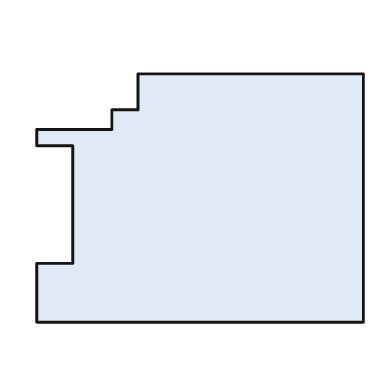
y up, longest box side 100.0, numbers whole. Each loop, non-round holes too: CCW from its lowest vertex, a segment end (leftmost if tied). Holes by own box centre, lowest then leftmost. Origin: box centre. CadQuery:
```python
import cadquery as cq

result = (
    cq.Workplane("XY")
    .moveTo(-50.0, -38.0)
    .lineTo(50.0, -38.0)
    .lineTo(50.0, 38.0)
    .lineTo(-19.0, 38.0)
    .lineTo(-19.0, 27.0)
    .lineTo(-27.0, 27.0)
    .lineTo(-27.0, 21.0)
    .lineTo(-50.0, 21.0)
    .lineTo(-50.0, 16.0)
    .lineTo(-39.0, 16.0)
    .lineTo(-39.0, -20.0)
    .lineTo(-50.0, -20.0)
    .close()
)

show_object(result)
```